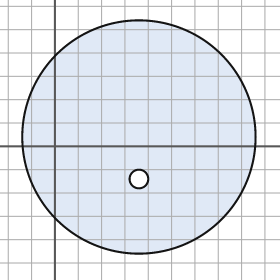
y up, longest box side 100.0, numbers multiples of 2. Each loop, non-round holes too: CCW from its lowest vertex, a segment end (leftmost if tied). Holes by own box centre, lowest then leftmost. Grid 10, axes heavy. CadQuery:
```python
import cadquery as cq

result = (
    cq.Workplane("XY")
    .moveTo(36.0, 4.0)
    .circle(50.0)
    .moveTo(36.0, -14.0)
    .circle(4.0)
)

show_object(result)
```